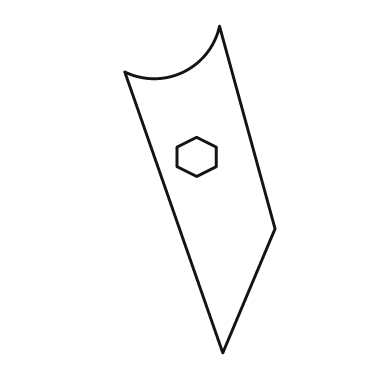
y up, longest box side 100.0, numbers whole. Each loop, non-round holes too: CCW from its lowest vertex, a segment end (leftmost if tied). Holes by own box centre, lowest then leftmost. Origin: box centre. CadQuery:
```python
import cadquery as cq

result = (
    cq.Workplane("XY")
    .moveTo(7.0, -50.0)
    .lineTo(23.0, -12.0)
    .lineTo(6.0, 50.0)
    .threePointArc((-5.0, 36.0), (-23.0, 36.0))
    .close()
    .moveTo(-1.0, 4.0)
    .lineTo(5.0, 7.0)
    .lineTo(5.0, 13.0)
    .lineTo(-1.0, 16.0)
    .lineTo(-7.0, 13.0)
    .lineTo(-7.0, 7.0)
    .close()
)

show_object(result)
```